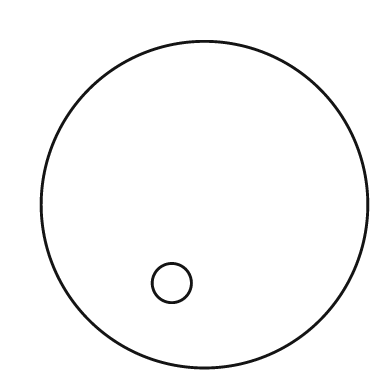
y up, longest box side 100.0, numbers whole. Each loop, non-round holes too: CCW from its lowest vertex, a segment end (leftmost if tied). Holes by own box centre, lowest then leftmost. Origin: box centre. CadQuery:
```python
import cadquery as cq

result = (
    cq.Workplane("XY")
    .moveTo(0.0, 0.0)
    .circle(50.0)
    .moveTo(-10.0, -24.0)
    .circle(6.0)
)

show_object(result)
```